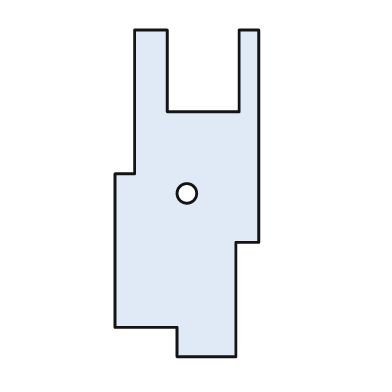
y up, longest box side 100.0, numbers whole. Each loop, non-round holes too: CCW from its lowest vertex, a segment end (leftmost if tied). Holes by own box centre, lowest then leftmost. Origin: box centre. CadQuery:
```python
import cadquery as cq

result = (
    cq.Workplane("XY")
    .moveTo(-3.0, -50.0)
    .lineTo(15.0, -50.0)
    .lineTo(15.0, -15.0)
    .lineTo(22.0, -15.0)
    .lineTo(22.0, 50.0)
    .lineTo(16.0, 50.0)
    .lineTo(16.0, 25.0)
    .lineTo(-6.0, 25.0)
    .lineTo(-6.0, 50.0)
    .lineTo(-16.0, 50.0)
    .lineTo(-16.0, 6.0)
    .lineTo(-22.0, 6.0)
    .lineTo(-22.0, -41.0)
    .lineTo(-3.0, -41.0)
    .close()
    .moveTo(0.0, 0.0)
    .circle(3.0)
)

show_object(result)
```